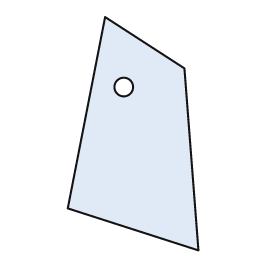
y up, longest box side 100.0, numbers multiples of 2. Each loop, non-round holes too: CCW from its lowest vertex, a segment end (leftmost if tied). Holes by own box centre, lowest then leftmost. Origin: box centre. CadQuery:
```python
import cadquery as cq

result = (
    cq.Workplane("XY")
    .moveTo(28.0, -50.0)
    .lineTo(22.0, 28.0)
    .lineTo(-12.0, 50.0)
    .lineTo(-28.0, -32.0)
    .close()
    .moveTo(-4.0, 20.0)
    .circle(4.0)
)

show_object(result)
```